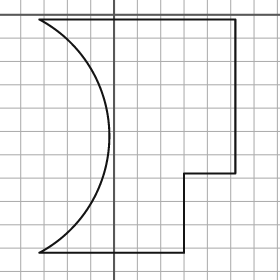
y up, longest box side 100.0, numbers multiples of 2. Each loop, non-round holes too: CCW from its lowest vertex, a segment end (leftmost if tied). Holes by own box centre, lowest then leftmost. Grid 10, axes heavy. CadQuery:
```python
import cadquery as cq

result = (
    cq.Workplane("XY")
    .moveTo(-32.0, -102.0)
    .lineTo(30.0, -102.0)
    .lineTo(30.0, -68.0)
    .lineTo(52.0, -68.0)
    .lineTo(52.0, -2.0)
    .lineTo(-32.0, -2.0)
    .threePointArc((-2.0, -52.0), (-32.0, -102.0))
    .close()
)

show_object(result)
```